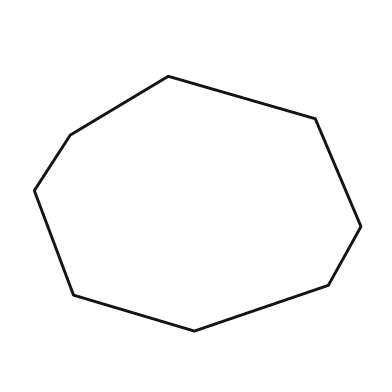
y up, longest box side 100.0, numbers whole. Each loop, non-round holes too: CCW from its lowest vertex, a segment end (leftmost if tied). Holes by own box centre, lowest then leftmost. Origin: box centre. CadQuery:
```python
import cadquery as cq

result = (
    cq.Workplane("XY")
    .moveTo(-1.0, -39.0)
    .lineTo(40.0, -25.0)
    .lineTo(50.0, -7.0)
    .lineTo(36.0, 26.0)
    .lineTo(-9.0, 39.0)
    .lineTo(-39.0, 21.0)
    .lineTo(-50.0, 4.0)
    .lineTo(-38.0, -28.0)
    .close()
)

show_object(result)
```